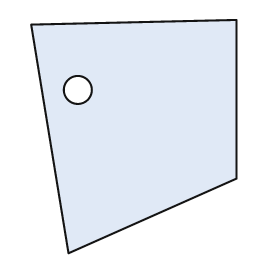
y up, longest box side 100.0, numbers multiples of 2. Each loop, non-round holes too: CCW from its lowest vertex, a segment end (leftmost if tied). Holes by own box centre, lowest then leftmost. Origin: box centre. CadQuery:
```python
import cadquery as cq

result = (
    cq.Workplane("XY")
    .moveTo(-28.0, -50.0)
    .lineTo(44.0, -18.0)
    .lineTo(44.0, 50.0)
    .lineTo(-44.0, 48.0)
    .close()
    .moveTo(-24.0, 20.0)
    .circle(6.0)
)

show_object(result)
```